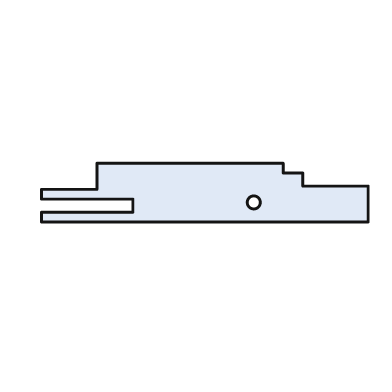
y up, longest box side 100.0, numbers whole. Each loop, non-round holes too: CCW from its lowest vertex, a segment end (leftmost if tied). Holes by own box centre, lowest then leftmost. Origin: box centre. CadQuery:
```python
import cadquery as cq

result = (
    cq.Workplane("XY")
    .moveTo(-50.0, -9.0)
    .lineTo(50.0, -9.0)
    .lineTo(50.0, 2.0)
    .lineTo(30.0, 2.0)
    .lineTo(30.0, 6.0)
    .lineTo(24.0, 6.0)
    .lineTo(24.0, 9.0)
    .lineTo(-33.0, 9.0)
    .lineTo(-33.0, 1.0)
    .lineTo(-50.0, 1.0)
    .lineTo(-50.0, -2.0)
    .lineTo(-22.0, -2.0)
    .lineTo(-22.0, -6.0)
    .lineTo(-50.0, -6.0)
    .close()
    .moveTo(15.0, -3.0)
    .circle(2.0)
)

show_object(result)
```